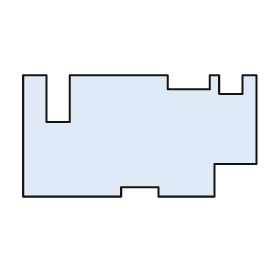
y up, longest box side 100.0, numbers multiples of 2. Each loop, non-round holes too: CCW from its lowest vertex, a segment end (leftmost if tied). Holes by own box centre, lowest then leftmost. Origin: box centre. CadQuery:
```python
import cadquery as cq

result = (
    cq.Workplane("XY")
    .moveTo(-50.0, -26.0)
    .lineTo(-8.0, -26.0)
    .lineTo(-8.0, -22.0)
    .lineTo(8.0, -22.0)
    .lineTo(8.0, -26.0)
    .lineTo(32.0, -26.0)
    .lineTo(32.0, -12.0)
    .lineTo(50.0, -12.0)
    .lineTo(50.0, 26.0)
    .lineTo(44.0, 26.0)
    .lineTo(44.0, 18.0)
    .lineTo(34.0, 18.0)
    .lineTo(34.0, 26.0)
    .lineTo(30.0, 26.0)
    .lineTo(30.0, 20.0)
    .lineTo(12.0, 20.0)
    .lineTo(12.0, 26.0)
    .lineTo(-30.0, 26.0)
    .lineTo(-30.0, 6.0)
    .lineTo(-40.0, 6.0)
    .lineTo(-40.0, 26.0)
    .lineTo(-50.0, 26.0)
    .close()
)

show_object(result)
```